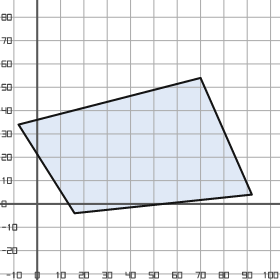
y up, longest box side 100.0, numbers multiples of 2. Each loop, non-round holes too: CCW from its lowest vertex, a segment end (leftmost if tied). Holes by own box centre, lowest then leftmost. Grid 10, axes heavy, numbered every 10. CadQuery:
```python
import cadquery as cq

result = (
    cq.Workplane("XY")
    .moveTo(16.0, -4.0)
    .lineTo(92.0, 4.0)
    .lineTo(70.0, 54.0)
    .lineTo(-8.0, 34.0)
    .close()
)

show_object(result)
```